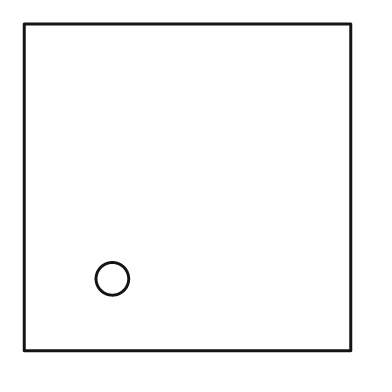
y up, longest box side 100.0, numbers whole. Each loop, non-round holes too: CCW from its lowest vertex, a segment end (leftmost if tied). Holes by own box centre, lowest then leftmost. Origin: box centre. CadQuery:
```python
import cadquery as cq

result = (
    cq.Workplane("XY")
    .moveTo(-50.0, -50.0)
    .lineTo(50.0, -50.0)
    .lineTo(50.0, 50.0)
    .lineTo(-50.0, 50.0)
    .close()
    .moveTo(-23.0, -28.0)
    .circle(5.0)
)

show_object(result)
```